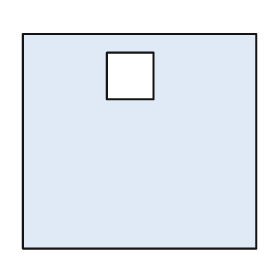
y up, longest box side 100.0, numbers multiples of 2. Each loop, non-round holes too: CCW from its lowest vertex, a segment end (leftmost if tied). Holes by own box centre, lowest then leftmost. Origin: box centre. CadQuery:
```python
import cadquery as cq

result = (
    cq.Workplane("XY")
    .moveTo(-50.0, -46.0)
    .lineTo(50.0, -46.0)
    .lineTo(50.0, 46.0)
    .lineTo(-50.0, 46.0)
    .close()
    .moveTo(-14.0, 18.0)
    .lineTo(6.0, 18.0)
    .lineTo(6.0, 38.0)
    .lineTo(-14.0, 38.0)
    .close()
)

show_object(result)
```